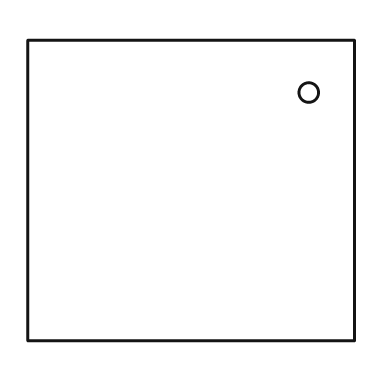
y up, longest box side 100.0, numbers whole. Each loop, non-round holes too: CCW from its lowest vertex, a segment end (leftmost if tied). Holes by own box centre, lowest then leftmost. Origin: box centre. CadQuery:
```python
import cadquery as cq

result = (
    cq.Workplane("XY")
    .moveTo(-50.0, -46.0)
    .lineTo(50.0, -46.0)
    .lineTo(50.0, 46.0)
    .lineTo(-50.0, 46.0)
    .close()
    .moveTo(36.0, 30.0)
    .circle(3.0)
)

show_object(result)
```